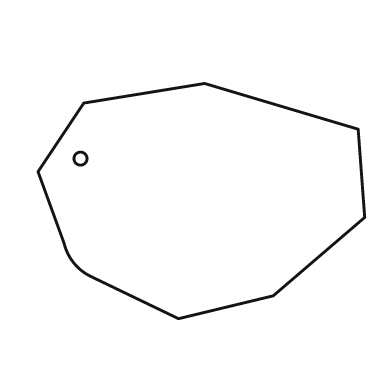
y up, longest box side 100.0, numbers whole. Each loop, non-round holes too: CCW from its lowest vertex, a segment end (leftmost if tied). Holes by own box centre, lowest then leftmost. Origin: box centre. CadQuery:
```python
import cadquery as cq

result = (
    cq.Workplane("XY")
    .moveTo(-7.0, -36.0)
    .lineTo(22.0, -29.0)
    .lineTo(50.0, -5.0)
    .lineTo(48.0, 22.0)
    .lineTo(1.0, 36.0)
    .lineTo(-36.0, 30.0)
    .lineTo(-50.0, 9.0)
    .lineTo(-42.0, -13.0)
    .threePointArc((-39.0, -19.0), (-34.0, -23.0))
    .close()
    .moveTo(-37.0, 13.0)
    .circle(2.0)
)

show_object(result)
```